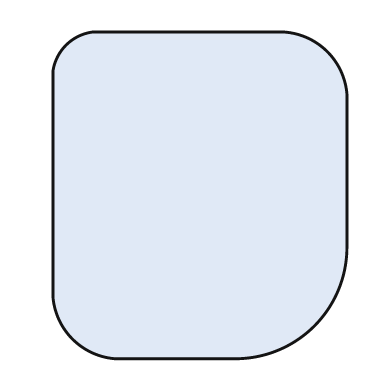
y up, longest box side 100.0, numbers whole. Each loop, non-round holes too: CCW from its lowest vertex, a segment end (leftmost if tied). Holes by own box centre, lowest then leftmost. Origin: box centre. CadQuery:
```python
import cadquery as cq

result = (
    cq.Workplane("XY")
    .moveTo(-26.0, -50.0)
    .lineTo(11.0, -50.0)
    .threePointArc((35.0, -40.0), (45.0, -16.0))
    .lineTo(45.0, 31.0)
    .threePointArc((39.0, 44.0), (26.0, 50.0))
    .lineTo(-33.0, 50.0)
    .threePointArc((-41.0, 46.0), (-45.0, 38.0))
    .lineTo(-45.0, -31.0)
    .threePointArc((-39.0, -44.0), (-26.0, -50.0))
    .close()
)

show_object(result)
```